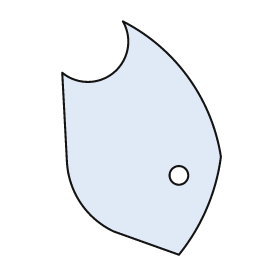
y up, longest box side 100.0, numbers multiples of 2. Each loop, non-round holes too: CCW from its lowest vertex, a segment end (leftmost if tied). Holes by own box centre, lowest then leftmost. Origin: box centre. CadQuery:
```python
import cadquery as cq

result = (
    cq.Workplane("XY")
    .moveTo(16.0, -50.0)
    .threePointArc((28.0, -30.0), (34.0, -8.0))
    .threePointArc((20.0, 26.0), (-8.0, 50.0))
    .threePointArc((-12.0, 28.0), (-34.0, 28.0))
    .lineTo(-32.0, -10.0)
    .threePointArc((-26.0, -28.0), (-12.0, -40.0))
    .close()
    .moveTo(16.0, -16.0)
    .circle(4.0)
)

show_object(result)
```